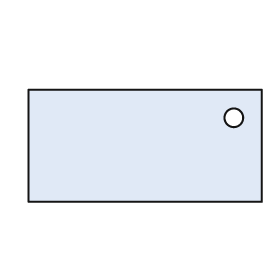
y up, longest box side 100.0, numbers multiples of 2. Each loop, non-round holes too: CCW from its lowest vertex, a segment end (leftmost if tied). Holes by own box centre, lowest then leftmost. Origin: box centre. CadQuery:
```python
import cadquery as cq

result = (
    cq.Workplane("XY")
    .moveTo(-50.0, -24.0)
    .lineTo(50.0, -24.0)
    .lineTo(50.0, 24.0)
    .lineTo(-50.0, 24.0)
    .close()
    .moveTo(38.0, 12.0)
    .circle(4.0)
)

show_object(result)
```